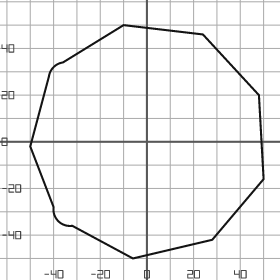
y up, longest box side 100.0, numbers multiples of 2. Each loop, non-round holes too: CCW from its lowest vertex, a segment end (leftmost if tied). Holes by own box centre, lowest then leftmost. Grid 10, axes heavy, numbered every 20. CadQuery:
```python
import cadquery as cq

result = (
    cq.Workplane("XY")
    .moveTo(-6.0, -50.0)
    .lineTo(28.0, -42.0)
    .lineTo(50.0, -16.0)
    .lineTo(48.0, 20.0)
    .lineTo(24.0, 46.0)
    .lineTo(-10.0, 50.0)
    .lineTo(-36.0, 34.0)
    .threePointArc((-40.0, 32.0), (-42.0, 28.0))
    .lineTo(-50.0, -2.0)
    .lineTo(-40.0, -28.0)
    .threePointArc((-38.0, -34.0), (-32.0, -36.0))
    .close()
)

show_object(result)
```